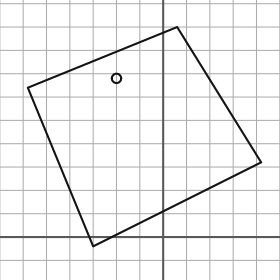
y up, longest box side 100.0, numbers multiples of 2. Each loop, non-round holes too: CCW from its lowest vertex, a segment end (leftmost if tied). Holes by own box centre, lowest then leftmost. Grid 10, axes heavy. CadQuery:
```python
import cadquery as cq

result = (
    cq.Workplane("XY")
    .moveTo(-30.0, -4.0)
    .lineTo(42.0, 32.0)
    .lineTo(6.0, 90.0)
    .lineTo(-58.0, 64.0)
    .close()
    .moveTo(-20.0, 68.0)
    .circle(2.0)
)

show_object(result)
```